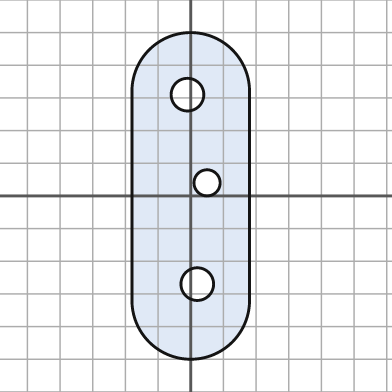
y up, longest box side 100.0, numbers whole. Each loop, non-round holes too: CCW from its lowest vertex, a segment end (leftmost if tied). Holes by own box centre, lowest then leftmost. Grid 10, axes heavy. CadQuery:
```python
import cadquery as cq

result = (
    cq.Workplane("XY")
    .moveTo(-18.0, -32.0)
    .threePointArc((0.0, -50.0), (18.0, -32.0))
    .lineTo(18.0, 32.0)
    .threePointArc((0.0, 50.0), (-18.0, 32.0))
    .close()
    .moveTo(2.0, -27.0)
    .circle(5.0)
    .moveTo(5.0, 4.0)
    .circle(4.0)
    .moveTo(-1.0, 31.0)
    .circle(5.0)
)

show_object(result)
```